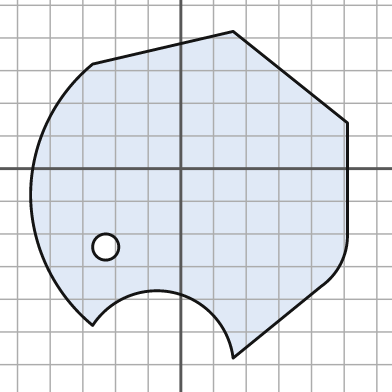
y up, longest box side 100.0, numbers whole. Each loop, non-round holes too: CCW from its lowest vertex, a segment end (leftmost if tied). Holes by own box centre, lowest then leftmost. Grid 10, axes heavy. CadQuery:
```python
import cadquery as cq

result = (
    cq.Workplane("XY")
    .moveTo(16.0, -58.0)
    .lineTo(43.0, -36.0)
    .threePointArc((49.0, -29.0), (51.0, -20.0))
    .lineTo(51.0, 14.0)
    .lineTo(16.0, 42.0)
    .lineTo(-27.0, 32.0)
    .threePointArc((-41.0, 14.0), (-46.0, -8.0))
    .threePointArc((-41.0, -30.0), (-27.0, -48.0))
    .threePointArc((-2.0, -38.0), (16.0, -58.0))
    .close()
    .moveTo(-23.0, -24.0)
    .circle(4.0)
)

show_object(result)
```